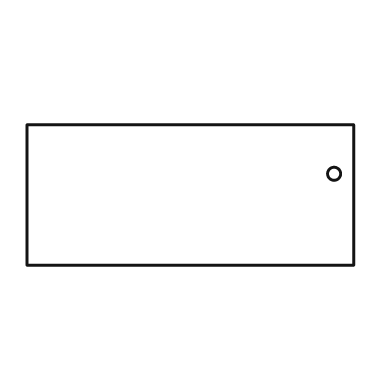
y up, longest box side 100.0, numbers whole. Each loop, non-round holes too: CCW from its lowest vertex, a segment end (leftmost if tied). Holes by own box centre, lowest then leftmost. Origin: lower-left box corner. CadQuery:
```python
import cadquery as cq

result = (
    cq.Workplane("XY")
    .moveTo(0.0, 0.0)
    .lineTo(100.0, 0.0)
    .lineTo(100.0, 43.0)
    .lineTo(0.0, 43.0)
    .close()
    .moveTo(94.0, 28.0)
    .circle(2.0)
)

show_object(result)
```